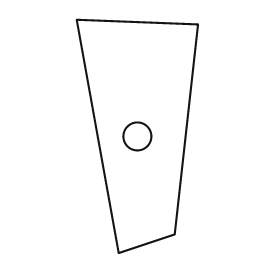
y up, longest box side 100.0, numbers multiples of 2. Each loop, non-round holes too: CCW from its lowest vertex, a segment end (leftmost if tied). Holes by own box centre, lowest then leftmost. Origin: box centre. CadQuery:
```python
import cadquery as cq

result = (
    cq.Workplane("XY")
    .moveTo(-8.0, -50.0)
    .lineTo(16.0, -42.0)
    .lineTo(26.0, 48.0)
    .lineTo(-26.0, 50.0)
    .close()
    .moveTo(0.0, 0.0)
    .circle(6.0)
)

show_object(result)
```